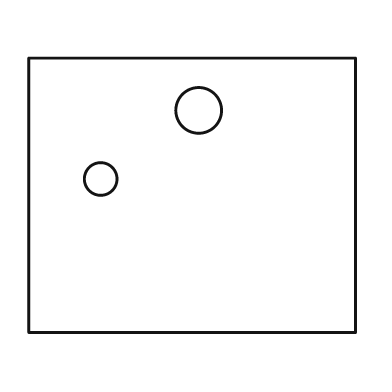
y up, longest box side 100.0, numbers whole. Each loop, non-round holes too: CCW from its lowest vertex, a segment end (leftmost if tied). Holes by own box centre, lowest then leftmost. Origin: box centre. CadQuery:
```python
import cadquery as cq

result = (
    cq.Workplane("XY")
    .moveTo(-50.0, -42.0)
    .lineTo(50.0, -42.0)
    .lineTo(50.0, 42.0)
    .lineTo(-50.0, 42.0)
    .close()
    .moveTo(-28.0, 5.0)
    .circle(5.0)
    .moveTo(2.0, 26.0)
    .circle(7.0)
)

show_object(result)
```